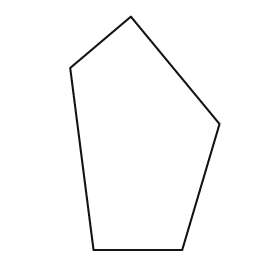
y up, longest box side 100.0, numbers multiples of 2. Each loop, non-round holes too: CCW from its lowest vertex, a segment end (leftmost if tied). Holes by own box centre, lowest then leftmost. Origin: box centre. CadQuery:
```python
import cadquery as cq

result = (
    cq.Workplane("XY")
    .moveTo(-22.0, -50.0)
    .lineTo(16.0, -50.0)
    .lineTo(32.0, 4.0)
    .lineTo(-6.0, 50.0)
    .lineTo(-32.0, 28.0)
    .close()
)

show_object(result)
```